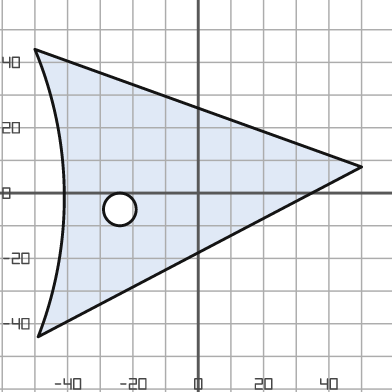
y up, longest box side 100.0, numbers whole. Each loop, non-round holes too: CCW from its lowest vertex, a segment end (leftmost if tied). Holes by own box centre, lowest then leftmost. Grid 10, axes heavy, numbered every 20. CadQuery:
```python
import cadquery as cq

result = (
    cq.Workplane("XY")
    .moveTo(-49.0, -44.0)
    .lineTo(50.0, 8.0)
    .lineTo(-50.0, 44.0)
    .threePointArc((-41.0, 0.0), (-49.0, -44.0))
    .close()
    .moveTo(-24.0, -5.0)
    .circle(5.0)
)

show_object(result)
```